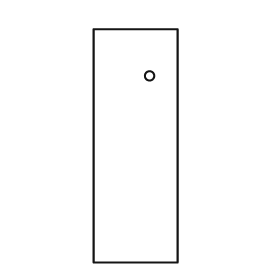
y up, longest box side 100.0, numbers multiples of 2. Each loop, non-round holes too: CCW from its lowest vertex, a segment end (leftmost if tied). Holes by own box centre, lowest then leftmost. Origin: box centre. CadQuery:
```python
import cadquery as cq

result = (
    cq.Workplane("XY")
    .moveTo(-18.0, -50.0)
    .lineTo(18.0, -50.0)
    .lineTo(18.0, 50.0)
    .lineTo(-18.0, 50.0)
    .close()
    .moveTo(6.0, 30.0)
    .circle(2.0)
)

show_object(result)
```